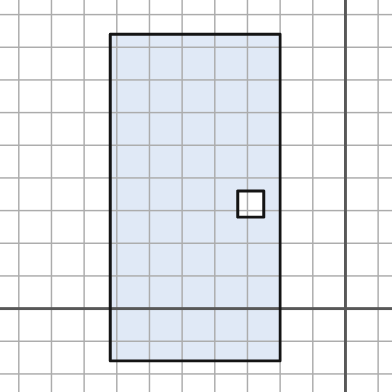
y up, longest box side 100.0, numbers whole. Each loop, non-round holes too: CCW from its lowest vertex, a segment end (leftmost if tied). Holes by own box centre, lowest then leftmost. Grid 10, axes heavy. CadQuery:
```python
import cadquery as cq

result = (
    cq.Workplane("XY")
    .moveTo(-72.0, -16.0)
    .lineTo(-20.0, -16.0)
    .lineTo(-20.0, 84.0)
    .lineTo(-72.0, 84.0)
    .close()
    .moveTo(-33.0, 28.0)
    .lineTo(-25.0, 28.0)
    .lineTo(-25.0, 36.0)
    .lineTo(-33.0, 36.0)
    .close()
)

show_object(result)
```